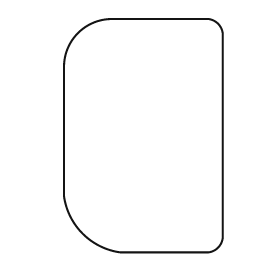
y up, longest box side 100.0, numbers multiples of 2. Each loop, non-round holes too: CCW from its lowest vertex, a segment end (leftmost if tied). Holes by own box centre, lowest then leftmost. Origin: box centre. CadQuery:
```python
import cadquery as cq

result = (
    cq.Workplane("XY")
    .moveTo(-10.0, -50.0)
    .lineTo(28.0, -50.0)
    .threePointArc((32.0, -48.0), (34.0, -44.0))
    .lineTo(34.0, 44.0)
    .threePointArc((32.0, 48.0), (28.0, 50.0))
    .lineTo(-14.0, 50.0)
    .threePointArc((-28.0, 44.0), (-34.0, 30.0))
    .lineTo(-34.0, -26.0)
    .threePointArc((-26.0, -42.0), (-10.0, -50.0))
    .close()
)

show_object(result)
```